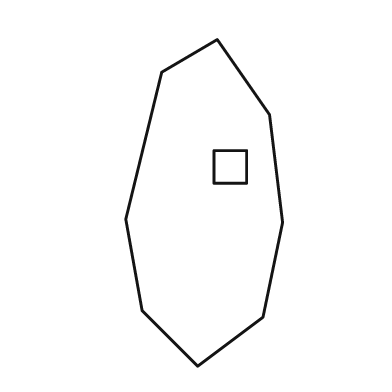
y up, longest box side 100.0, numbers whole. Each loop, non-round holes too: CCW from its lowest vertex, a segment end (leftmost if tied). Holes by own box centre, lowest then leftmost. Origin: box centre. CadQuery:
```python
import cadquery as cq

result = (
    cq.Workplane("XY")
    .moveTo(-2.0, -50.0)
    .lineTo(18.0, -35.0)
    .lineTo(24.0, -6.0)
    .lineTo(20.0, 27.0)
    .lineTo(4.0, 50.0)
    .lineTo(-13.0, 40.0)
    .lineTo(-24.0, -5.0)
    .lineTo(-19.0, -33.0)
    .close()
    .moveTo(3.0, 6.0)
    .lineTo(13.0, 6.0)
    .lineTo(13.0, 16.0)
    .lineTo(3.0, 16.0)
    .close()
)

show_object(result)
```